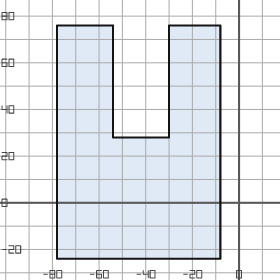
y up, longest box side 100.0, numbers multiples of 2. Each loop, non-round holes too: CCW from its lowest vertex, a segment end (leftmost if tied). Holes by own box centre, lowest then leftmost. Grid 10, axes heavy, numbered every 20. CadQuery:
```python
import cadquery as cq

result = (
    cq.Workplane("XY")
    .moveTo(-78.0, -24.0)
    .lineTo(-8.0, -24.0)
    .lineTo(-8.0, 76.0)
    .lineTo(-30.0, 76.0)
    .lineTo(-30.0, 28.0)
    .lineTo(-54.0, 28.0)
    .lineTo(-54.0, 76.0)
    .lineTo(-78.0, 76.0)
    .close()
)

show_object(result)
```